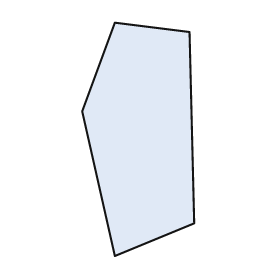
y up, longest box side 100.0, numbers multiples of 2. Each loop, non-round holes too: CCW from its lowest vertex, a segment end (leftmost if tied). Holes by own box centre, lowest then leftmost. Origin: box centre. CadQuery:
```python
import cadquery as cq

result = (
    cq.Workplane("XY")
    .moveTo(-10.0, -50.0)
    .lineTo(24.0, -36.0)
    .lineTo(22.0, 46.0)
    .lineTo(-10.0, 50.0)
    .lineTo(-24.0, 12.0)
    .close()
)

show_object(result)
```